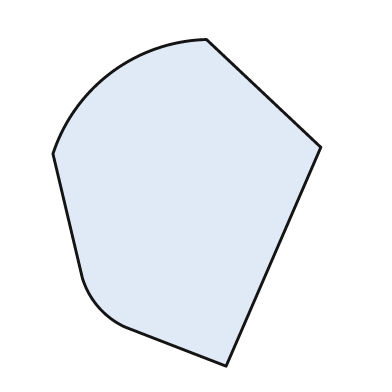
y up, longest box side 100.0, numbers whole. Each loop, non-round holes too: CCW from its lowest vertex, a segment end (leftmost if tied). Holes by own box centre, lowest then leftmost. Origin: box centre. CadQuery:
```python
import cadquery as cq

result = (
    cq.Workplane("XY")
    .moveTo(12.0, -50.0)
    .lineTo(41.0, 17.0)
    .lineTo(6.0, 50.0)
    .threePointArc((-23.0, 40.0), (-41.0, 15.0))
    .lineTo(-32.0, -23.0)
    .threePointArc((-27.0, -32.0), (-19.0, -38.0))
    .close()
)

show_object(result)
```